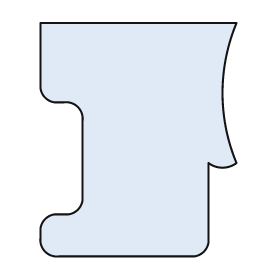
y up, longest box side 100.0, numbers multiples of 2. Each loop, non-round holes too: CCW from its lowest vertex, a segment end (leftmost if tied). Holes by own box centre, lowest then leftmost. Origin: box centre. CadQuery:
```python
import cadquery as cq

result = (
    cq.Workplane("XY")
    .moveTo(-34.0, -50.0)
    .lineTo(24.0, -50.0)
    .threePointArc((28.0, -48.0), (30.0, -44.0))
    .lineTo(30.0, -10.0)
    .threePointArc((36.0, -12.0), (42.0, -10.0))
    .threePointArc((36.0, 20.0), (42.0, 50.0))
    .lineTo(-42.0, 50.0)
    .lineTo(-42.0, 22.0)
    .threePointArc((-40.0, 18.0), (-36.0, 16.0))
    .lineTo(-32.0, 16.0)
    .threePointArc((-26.0, 14.0), (-24.0, 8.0))
    .lineTo(-24.0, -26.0)
    .threePointArc((-26.0, -30.0), (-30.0, -32.0))
    .lineTo(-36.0, -32.0)
    .threePointArc((-40.0, -34.0), (-42.0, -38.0))
    .lineTo(-42.0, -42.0)
    .threePointArc((-40.0, -48.0), (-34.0, -50.0))
    .close()
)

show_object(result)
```